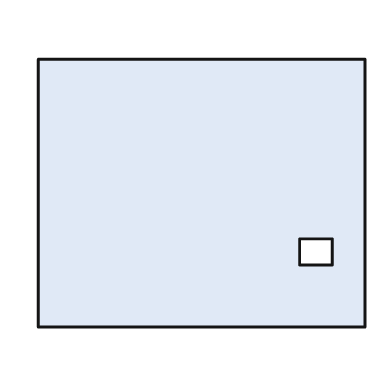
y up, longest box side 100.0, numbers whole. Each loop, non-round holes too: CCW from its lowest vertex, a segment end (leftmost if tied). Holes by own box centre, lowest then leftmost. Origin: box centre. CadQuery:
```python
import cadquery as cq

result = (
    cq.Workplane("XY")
    .moveTo(-50.0, -41.0)
    .lineTo(50.0, -41.0)
    .lineTo(50.0, 41.0)
    .lineTo(-50.0, 41.0)
    .close()
    .moveTo(30.0, -22.0)
    .lineTo(40.0, -22.0)
    .lineTo(40.0, -14.0)
    .lineTo(30.0, -14.0)
    .close()
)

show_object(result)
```